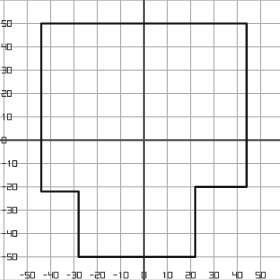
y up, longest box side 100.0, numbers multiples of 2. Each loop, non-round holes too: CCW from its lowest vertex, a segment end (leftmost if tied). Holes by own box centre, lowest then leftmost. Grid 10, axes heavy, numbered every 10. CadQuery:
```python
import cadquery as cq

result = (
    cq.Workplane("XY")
    .moveTo(-28.0, -50.0)
    .lineTo(22.0, -50.0)
    .lineTo(22.0, -20.0)
    .lineTo(44.0, -20.0)
    .lineTo(44.0, 50.0)
    .lineTo(-44.0, 50.0)
    .lineTo(-44.0, -22.0)
    .lineTo(-28.0, -22.0)
    .close()
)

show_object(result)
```